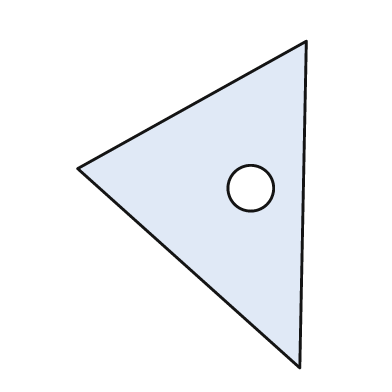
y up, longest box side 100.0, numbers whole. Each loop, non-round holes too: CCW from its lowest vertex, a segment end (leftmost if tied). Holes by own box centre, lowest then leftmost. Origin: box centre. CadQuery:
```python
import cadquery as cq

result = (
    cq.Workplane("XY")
    .moveTo(33.0, -50.0)
    .lineTo(35.0, 50.0)
    .lineTo(-35.0, 11.0)
    .close()
    .moveTo(18.0, 5.0)
    .circle(7.0)
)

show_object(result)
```